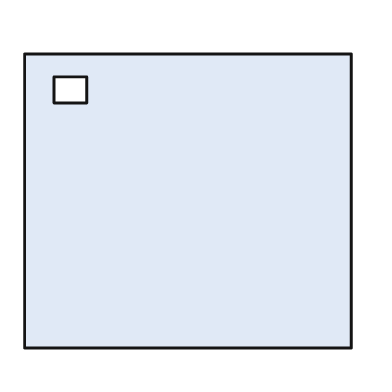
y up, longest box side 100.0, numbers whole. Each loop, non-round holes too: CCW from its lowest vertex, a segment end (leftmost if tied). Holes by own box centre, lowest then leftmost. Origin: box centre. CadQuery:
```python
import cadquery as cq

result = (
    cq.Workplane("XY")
    .moveTo(-50.0, -45.0)
    .lineTo(50.0, -45.0)
    .lineTo(50.0, 45.0)
    .lineTo(-50.0, 45.0)
    .close()
    .moveTo(-41.0, 30.0)
    .lineTo(-31.0, 30.0)
    .lineTo(-31.0, 38.0)
    .lineTo(-41.0, 38.0)
    .close()
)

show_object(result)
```